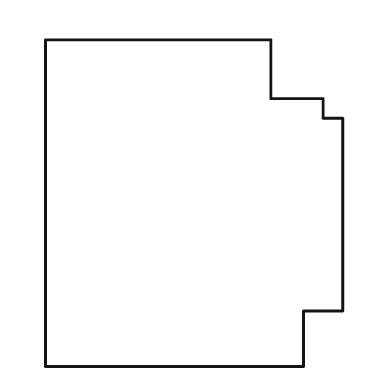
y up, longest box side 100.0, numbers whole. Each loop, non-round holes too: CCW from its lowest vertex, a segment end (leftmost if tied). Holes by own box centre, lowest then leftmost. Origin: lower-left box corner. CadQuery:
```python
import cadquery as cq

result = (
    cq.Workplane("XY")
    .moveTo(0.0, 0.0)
    .lineTo(79.0, 0.0)
    .lineTo(79.0, 17.0)
    .lineTo(91.0, 17.0)
    .lineTo(91.0, 76.0)
    .lineTo(85.0, 76.0)
    .lineTo(85.0, 82.0)
    .lineTo(69.0, 82.0)
    .lineTo(69.0, 100.0)
    .lineTo(0.0, 100.0)
    .close()
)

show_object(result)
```